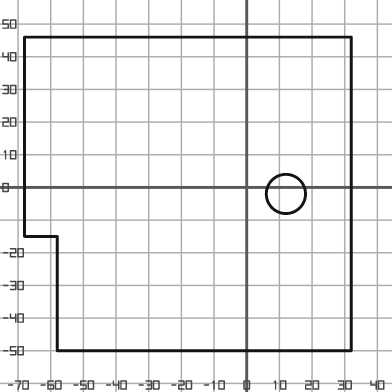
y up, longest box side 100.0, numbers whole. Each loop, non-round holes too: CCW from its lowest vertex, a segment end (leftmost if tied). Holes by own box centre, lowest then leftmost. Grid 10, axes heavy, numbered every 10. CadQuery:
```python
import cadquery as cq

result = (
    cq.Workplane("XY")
    .moveTo(-58.0, -50.0)
    .lineTo(32.0, -50.0)
    .lineTo(32.0, 46.0)
    .lineTo(-68.0, 46.0)
    .lineTo(-68.0, -15.0)
    .lineTo(-58.0, -15.0)
    .close()
    .moveTo(12.0, -2.0)
    .circle(6.0)
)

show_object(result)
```